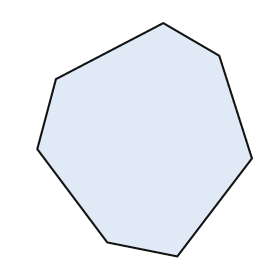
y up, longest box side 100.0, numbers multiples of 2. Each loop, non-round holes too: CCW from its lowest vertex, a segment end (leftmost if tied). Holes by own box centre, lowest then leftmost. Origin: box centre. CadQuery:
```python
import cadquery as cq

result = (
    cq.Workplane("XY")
    .moveTo(14.0, -50.0)
    .lineTo(46.0, -8.0)
    .lineTo(32.0, 36.0)
    .lineTo(8.0, 50.0)
    .lineTo(-38.0, 26.0)
    .lineTo(-46.0, -4.0)
    .lineTo(-16.0, -44.0)
    .close()
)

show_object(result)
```